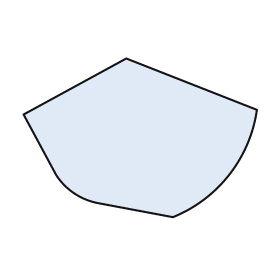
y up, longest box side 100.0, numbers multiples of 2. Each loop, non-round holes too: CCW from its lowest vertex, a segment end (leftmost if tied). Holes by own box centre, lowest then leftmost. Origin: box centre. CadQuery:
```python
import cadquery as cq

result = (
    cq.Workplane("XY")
    .moveTo(14.0, -34.0)
    .threePointArc((38.0, -16.0), (50.0, 12.0))
    .lineTo(-6.0, 34.0)
    .lineTo(-50.0, 10.0)
    .lineTo(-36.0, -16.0)
    .threePointArc((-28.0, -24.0), (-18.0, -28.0))
    .close()
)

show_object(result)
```